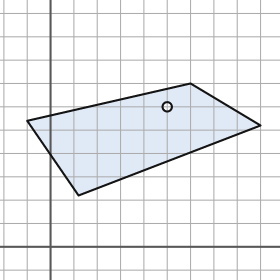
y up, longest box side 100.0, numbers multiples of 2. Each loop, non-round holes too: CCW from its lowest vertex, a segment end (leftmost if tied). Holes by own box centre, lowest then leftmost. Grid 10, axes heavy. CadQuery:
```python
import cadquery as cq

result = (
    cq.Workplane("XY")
    .moveTo(12.0, 22.0)
    .lineTo(90.0, 52.0)
    .lineTo(60.0, 70.0)
    .lineTo(-10.0, 54.0)
    .close()
    .moveTo(50.0, 60.0)
    .circle(2.0)
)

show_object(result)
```